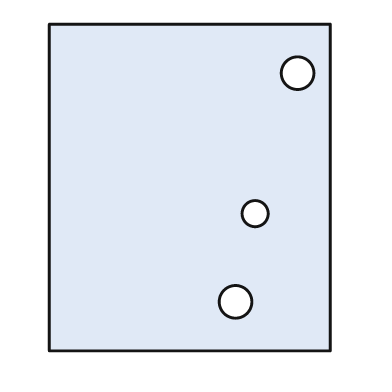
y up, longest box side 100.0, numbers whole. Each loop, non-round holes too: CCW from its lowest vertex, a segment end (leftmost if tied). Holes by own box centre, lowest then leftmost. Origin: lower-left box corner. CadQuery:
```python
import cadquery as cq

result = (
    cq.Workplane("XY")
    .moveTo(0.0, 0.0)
    .lineTo(86.0, 0.0)
    .lineTo(86.0, 100.0)
    .lineTo(0.0, 100.0)
    .close()
    .moveTo(57.0, 15.0)
    .circle(5.0)
    .moveTo(63.0, 42.0)
    .circle(4.0)
    .moveTo(76.0, 85.0)
    .circle(5.0)
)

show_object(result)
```